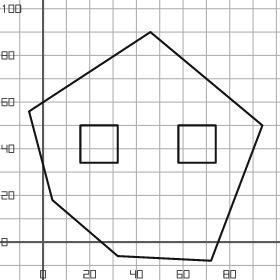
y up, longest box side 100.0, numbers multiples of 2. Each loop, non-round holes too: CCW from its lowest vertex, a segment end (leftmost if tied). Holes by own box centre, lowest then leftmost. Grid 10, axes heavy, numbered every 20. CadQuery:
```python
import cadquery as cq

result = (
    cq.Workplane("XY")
    .moveTo(72.0, -8.0)
    .lineTo(94.0, 50.0)
    .lineTo(46.0, 90.0)
    .lineTo(-6.0, 56.0)
    .lineTo(4.0, 18.0)
    .lineTo(32.0, -6.0)
    .close()
    .moveTo(16.0, 34.0)
    .lineTo(32.0, 34.0)
    .lineTo(32.0, 50.0)
    .lineTo(16.0, 50.0)
    .close()
    .moveTo(58.0, 34.0)
    .lineTo(74.0, 34.0)
    .lineTo(74.0, 50.0)
    .lineTo(58.0, 50.0)
    .close()
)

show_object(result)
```